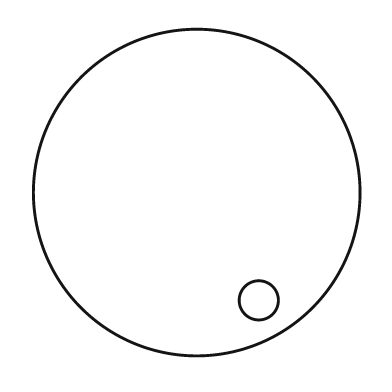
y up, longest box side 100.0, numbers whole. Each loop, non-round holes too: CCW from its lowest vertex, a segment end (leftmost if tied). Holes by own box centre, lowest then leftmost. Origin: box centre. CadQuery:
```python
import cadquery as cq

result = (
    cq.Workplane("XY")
    .moveTo(0.0, 0.0)
    .circle(50.0)
    .moveTo(19.0, -33.0)
    .circle(6.0)
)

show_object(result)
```